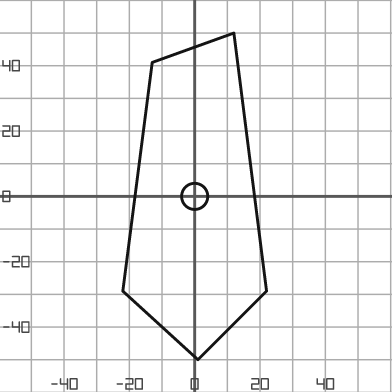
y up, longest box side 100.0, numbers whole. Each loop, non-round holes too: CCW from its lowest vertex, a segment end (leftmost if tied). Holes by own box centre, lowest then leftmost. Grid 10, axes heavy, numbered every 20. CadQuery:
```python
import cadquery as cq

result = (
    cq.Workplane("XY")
    .moveTo(1.0, -50.0)
    .lineTo(22.0, -29.0)
    .lineTo(12.0, 50.0)
    .lineTo(-13.0, 41.0)
    .lineTo(-22.0, -29.0)
    .close()
    .moveTo(0.0, 0.0)
    .circle(4.0)
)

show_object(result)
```